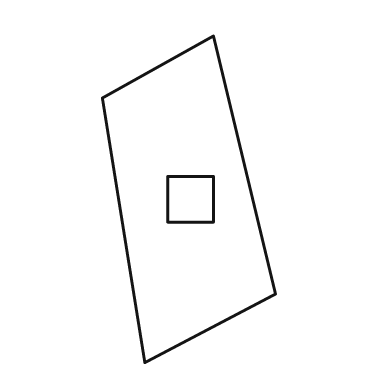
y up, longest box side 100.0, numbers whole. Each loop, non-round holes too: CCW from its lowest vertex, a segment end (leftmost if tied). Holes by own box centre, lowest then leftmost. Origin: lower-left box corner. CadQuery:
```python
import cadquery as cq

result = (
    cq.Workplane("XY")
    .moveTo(13.0, 0.0)
    .lineTo(53.0, 21.0)
    .lineTo(34.0, 100.0)
    .lineTo(0.0, 81.0)
    .close()
    .moveTo(20.0, 43.0)
    .lineTo(34.0, 43.0)
    .lineTo(34.0, 57.0)
    .lineTo(20.0, 57.0)
    .close()
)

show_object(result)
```